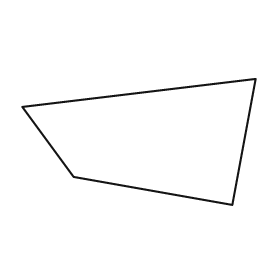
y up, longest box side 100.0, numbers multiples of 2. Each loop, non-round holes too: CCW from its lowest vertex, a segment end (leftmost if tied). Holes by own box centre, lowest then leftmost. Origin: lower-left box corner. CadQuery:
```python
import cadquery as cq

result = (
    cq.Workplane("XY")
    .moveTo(90.0, 0.0)
    .lineTo(100.0, 54.0)
    .lineTo(0.0, 42.0)
    .lineTo(22.0, 12.0)
    .close()
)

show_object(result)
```